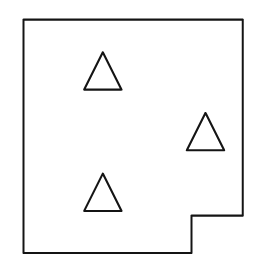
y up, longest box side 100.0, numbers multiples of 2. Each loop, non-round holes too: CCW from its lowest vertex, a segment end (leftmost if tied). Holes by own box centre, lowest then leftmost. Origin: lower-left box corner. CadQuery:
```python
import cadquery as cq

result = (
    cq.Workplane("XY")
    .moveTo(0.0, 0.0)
    .lineTo(72.0, 0.0)
    .lineTo(72.0, 16.0)
    .lineTo(94.0, 16.0)
    .lineTo(94.0, 100.0)
    .lineTo(0.0, 100.0)
    .close()
    .moveTo(26.0, 18.0)
    .lineTo(42.0, 18.0)
    .lineTo(34.0, 34.0)
    .close()
    .moveTo(70.0, 44.0)
    .lineTo(86.0, 44.0)
    .lineTo(78.0, 60.0)
    .close()
    .moveTo(26.0, 70.0)
    .lineTo(42.0, 70.0)
    .lineTo(34.0, 86.0)
    .close()
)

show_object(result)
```